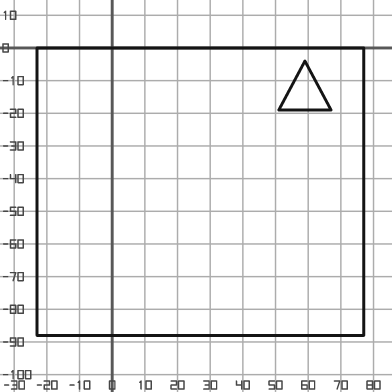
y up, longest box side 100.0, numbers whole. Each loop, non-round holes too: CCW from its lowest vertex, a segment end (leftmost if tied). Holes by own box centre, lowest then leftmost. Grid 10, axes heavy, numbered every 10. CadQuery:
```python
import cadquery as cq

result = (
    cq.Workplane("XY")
    .moveTo(-23.0, -88.0)
    .lineTo(77.0, -88.0)
    .lineTo(77.0, 0.0)
    .lineTo(-23.0, 0.0)
    .close()
    .moveTo(51.0, -19.0)
    .lineTo(67.0, -19.0)
    .lineTo(59.0, -4.0)
    .close()
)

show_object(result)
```